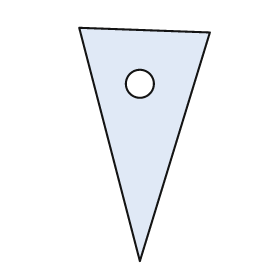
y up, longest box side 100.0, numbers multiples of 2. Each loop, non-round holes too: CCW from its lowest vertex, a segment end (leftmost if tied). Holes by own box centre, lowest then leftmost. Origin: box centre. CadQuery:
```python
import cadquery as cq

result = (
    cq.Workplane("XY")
    .moveTo(-2.0, -50.0)
    .lineTo(28.0, 48.0)
    .lineTo(-28.0, 50.0)
    .close()
    .moveTo(-2.0, 26.0)
    .circle(6.0)
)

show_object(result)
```